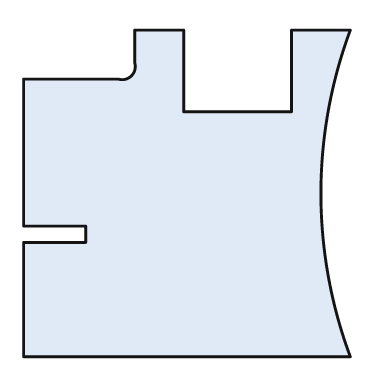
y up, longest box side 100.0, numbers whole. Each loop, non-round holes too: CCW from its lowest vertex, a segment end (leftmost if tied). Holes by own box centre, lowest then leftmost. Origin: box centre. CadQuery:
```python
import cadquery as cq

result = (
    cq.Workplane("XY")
    .moveTo(-50.0, -50.0)
    .lineTo(50.0, -50.0)
    .threePointArc((41.0, 0.0), (50.0, 50.0))
    .lineTo(32.0, 50.0)
    .lineTo(32.0, 25.0)
    .lineTo(-1.0, 25.0)
    .lineTo(-1.0, 50.0)
    .lineTo(-16.0, 50.0)
    .lineTo(-16.0, 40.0)
    .threePointArc((-17.0, 36.0), (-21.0, 35.0))
    .lineTo(-50.0, 35.0)
    .lineTo(-50.0, -10.0)
    .lineTo(-31.0, -10.0)
    .lineTo(-31.0, -15.0)
    .lineTo(-50.0, -15.0)
    .close()
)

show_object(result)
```